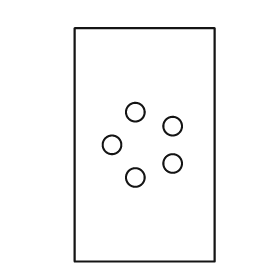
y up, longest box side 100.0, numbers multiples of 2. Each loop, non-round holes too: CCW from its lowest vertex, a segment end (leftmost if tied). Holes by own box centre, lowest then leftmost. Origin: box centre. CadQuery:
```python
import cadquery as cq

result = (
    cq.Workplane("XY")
    .moveTo(-30.0, -50.0)
    .lineTo(30.0, -50.0)
    .lineTo(30.0, 50.0)
    .lineTo(-30.0, 50.0)
    .close()
    .moveTo(-4.0, -14.0)
    .circle(4.0)
    .moveTo(12.0, -8.0)
    .circle(4.0)
    .moveTo(-14.0, 0.0)
    .circle(4.0)
    .moveTo(12.0, 8.0)
    .circle(4.0)
    .moveTo(-4.0, 14.0)
    .circle(4.0)
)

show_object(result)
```